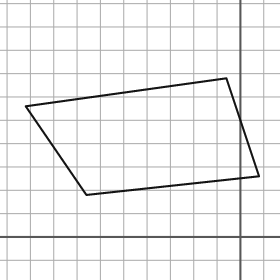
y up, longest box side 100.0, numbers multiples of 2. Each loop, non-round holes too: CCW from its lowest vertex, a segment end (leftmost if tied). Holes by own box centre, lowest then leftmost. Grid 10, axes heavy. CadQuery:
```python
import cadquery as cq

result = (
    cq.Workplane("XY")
    .moveTo(-66.0, 18.0)
    .lineTo(8.0, 26.0)
    .lineTo(-6.0, 68.0)
    .lineTo(-92.0, 56.0)
    .close()
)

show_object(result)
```